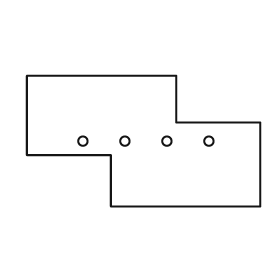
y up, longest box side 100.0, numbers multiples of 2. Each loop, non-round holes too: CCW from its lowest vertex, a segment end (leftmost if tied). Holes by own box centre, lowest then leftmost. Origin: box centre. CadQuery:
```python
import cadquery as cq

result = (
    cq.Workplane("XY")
    .moveTo(-14.0, -28.0)
    .lineTo(50.0, -28.0)
    .lineTo(50.0, 8.0)
    .lineTo(14.0, 8.0)
    .lineTo(14.0, 28.0)
    .lineTo(-50.0, 28.0)
    .lineTo(-50.0, -6.0)
    .lineTo(-14.0, -6.0)
    .close()
    .moveTo(-26.0, 0.0)
    .circle(2.0)
    .moveTo(-8.0, 0.0)
    .circle(2.0)
    .moveTo(10.0, 0.0)
    .circle(2.0)
    .moveTo(28.0, 0.0)
    .circle(2.0)
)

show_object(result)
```